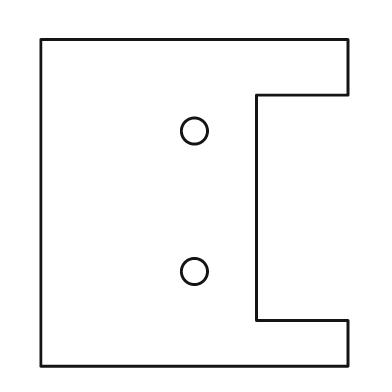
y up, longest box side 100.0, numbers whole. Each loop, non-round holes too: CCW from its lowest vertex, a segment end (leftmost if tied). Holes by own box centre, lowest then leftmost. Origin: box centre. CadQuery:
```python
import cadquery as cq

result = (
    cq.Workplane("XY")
    .moveTo(-47.0, -50.0)
    .lineTo(47.0, -50.0)
    .lineTo(47.0, -36.0)
    .lineTo(19.0, -36.0)
    .lineTo(19.0, 33.0)
    .lineTo(47.0, 33.0)
    .lineTo(47.0, 50.0)
    .lineTo(-47.0, 50.0)
    .close()
    .moveTo(0.0, -21.0)
    .circle(4.0)
    .moveTo(0.0, 22.0)
    .circle(4.0)
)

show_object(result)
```